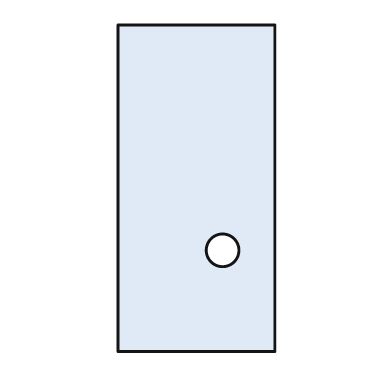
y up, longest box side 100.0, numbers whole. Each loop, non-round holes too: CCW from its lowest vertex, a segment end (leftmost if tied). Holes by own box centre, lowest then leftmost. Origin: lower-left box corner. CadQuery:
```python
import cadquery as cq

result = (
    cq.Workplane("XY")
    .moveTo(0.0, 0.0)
    .lineTo(48.0, 0.0)
    .lineTo(48.0, 100.0)
    .lineTo(0.0, 100.0)
    .close()
    .moveTo(32.0, 31.0)
    .circle(5.0)
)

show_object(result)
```